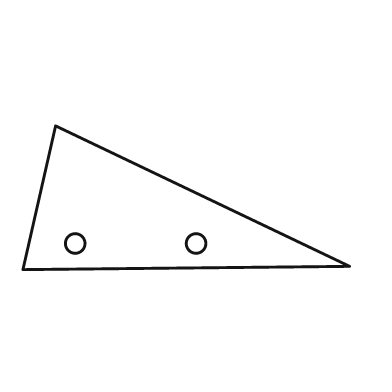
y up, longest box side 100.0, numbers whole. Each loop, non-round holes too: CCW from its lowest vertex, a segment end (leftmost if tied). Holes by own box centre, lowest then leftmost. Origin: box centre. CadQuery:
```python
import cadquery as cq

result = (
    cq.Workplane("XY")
    .moveTo(-50.0, -22.0)
    .lineTo(50.0, -21.0)
    .lineTo(-40.0, 22.0)
    .close()
    .moveTo(-34.0, -14.0)
    .circle(3.0)
    .moveTo(3.0, -14.0)
    .circle(3.0)
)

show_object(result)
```